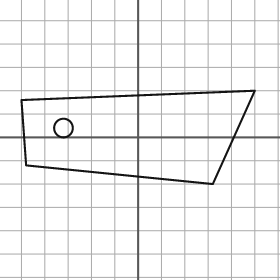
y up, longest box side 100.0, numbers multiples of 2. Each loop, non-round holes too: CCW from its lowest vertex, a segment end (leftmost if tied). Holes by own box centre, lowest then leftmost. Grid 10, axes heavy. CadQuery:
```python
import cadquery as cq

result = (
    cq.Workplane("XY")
    .moveTo(32.0, -20.0)
    .lineTo(50.0, 20.0)
    .lineTo(-50.0, 16.0)
    .lineTo(-48.0, -12.0)
    .close()
    .moveTo(-32.0, 4.0)
    .circle(4.0)
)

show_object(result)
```